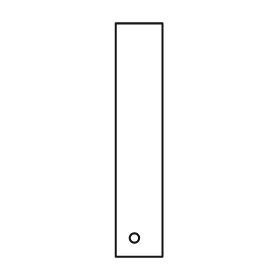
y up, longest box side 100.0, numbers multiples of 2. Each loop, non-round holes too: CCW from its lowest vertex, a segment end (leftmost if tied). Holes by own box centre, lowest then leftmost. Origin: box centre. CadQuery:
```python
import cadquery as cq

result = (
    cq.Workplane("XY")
    .moveTo(-10.0, -50.0)
    .lineTo(10.0, -50.0)
    .lineTo(10.0, 50.0)
    .lineTo(-10.0, 50.0)
    .close()
    .moveTo(-2.0, -42.0)
    .circle(2.0)
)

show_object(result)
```